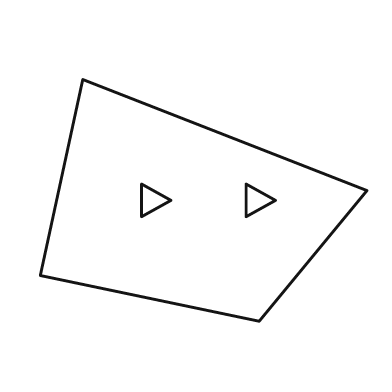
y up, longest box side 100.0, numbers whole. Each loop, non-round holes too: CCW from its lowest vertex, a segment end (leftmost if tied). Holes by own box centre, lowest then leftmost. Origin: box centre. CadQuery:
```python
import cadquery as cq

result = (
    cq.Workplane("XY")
    .moveTo(17.0, -37.0)
    .lineTo(50.0, 3.0)
    .lineTo(-37.0, 37.0)
    .lineTo(-50.0, -23.0)
    .close()
    .moveTo(-19.0, -5.0)
    .lineTo(-10.0, 0.0)
    .lineTo(-19.0, 5.0)
    .close()
    .moveTo(13.0, -5.0)
    .lineTo(22.0, 0.0)
    .lineTo(13.0, 5.0)
    .close()
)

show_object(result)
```